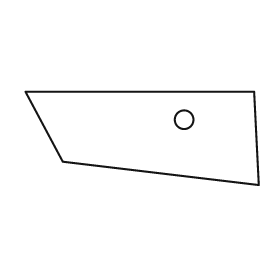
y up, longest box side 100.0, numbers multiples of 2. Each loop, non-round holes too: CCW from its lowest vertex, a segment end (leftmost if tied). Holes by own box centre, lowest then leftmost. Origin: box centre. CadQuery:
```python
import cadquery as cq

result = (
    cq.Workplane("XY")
    .moveTo(50.0, -20.0)
    .lineTo(48.0, 20.0)
    .lineTo(-50.0, 20.0)
    .lineTo(-34.0, -10.0)
    .close()
    .moveTo(18.0, 8.0)
    .circle(4.0)
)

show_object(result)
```